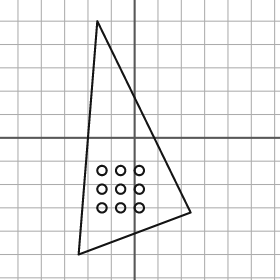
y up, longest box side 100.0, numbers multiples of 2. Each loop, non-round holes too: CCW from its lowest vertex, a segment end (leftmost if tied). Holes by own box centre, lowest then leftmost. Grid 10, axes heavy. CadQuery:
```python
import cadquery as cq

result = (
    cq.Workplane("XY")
    .moveTo(-24.0, -50.0)
    .lineTo(24.0, -32.0)
    .lineTo(-16.0, 50.0)
    .close()
    .moveTo(-14.0, -30.0)
    .circle(2.0)
    .moveTo(-6.0, -30.0)
    .circle(2.0)
    .moveTo(2.0, -30.0)
    .circle(2.0)
    .moveTo(-14.0, -22.0)
    .circle(2.0)
    .moveTo(-6.0, -22.0)
    .circle(2.0)
    .moveTo(2.0, -22.0)
    .circle(2.0)
    .moveTo(-14.0, -14.0)
    .circle(2.0)
    .moveTo(-6.0, -14.0)
    .circle(2.0)
    .moveTo(2.0, -14.0)
    .circle(2.0)
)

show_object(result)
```